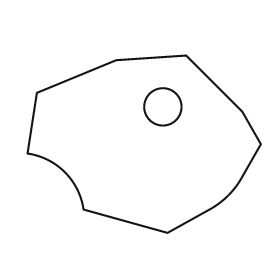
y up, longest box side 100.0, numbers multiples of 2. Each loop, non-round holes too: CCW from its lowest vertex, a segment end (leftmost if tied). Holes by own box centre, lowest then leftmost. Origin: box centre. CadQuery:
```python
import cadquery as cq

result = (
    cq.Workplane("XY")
    .moveTo(10.0, -38.0)
    .lineTo(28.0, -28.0)
    .threePointArc((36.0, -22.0), (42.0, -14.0))
    .lineTo(50.0, 0.0)
    .lineTo(42.0, 14.0)
    .lineTo(18.0, 38.0)
    .lineTo(-12.0, 36.0)
    .lineTo(-46.0, 22.0)
    .lineTo(-50.0, -4.0)
    .threePointArc((-34.0, -12.0), (-26.0, -28.0))
    .close()
    .moveTo(8.0, 16.0)
    .circle(8.0)
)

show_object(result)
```